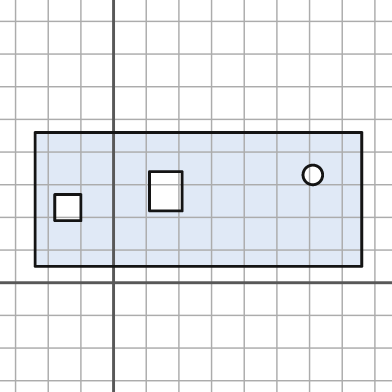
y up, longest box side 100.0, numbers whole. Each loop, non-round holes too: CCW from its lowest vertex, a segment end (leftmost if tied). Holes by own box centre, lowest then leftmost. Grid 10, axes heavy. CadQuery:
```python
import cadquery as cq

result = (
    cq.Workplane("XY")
    .moveTo(-24.0, 5.0)
    .lineTo(76.0, 5.0)
    .lineTo(76.0, 46.0)
    .lineTo(-24.0, 46.0)
    .close()
    .moveTo(-18.0, 19.0)
    .lineTo(-10.0, 19.0)
    .lineTo(-10.0, 27.0)
    .lineTo(-18.0, 27.0)
    .close()
    .moveTo(11.0, 22.0)
    .lineTo(21.0, 22.0)
    .lineTo(21.0, 34.0)
    .lineTo(11.0, 34.0)
    .close()
    .moveTo(61.0, 33.0)
    .circle(3.0)
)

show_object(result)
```